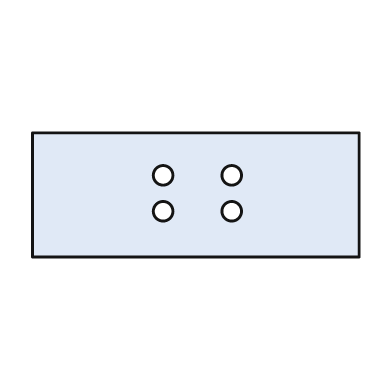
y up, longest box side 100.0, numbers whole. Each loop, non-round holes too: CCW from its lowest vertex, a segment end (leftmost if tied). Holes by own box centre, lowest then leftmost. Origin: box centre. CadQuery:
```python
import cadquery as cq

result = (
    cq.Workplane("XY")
    .moveTo(-50.0, -19.0)
    .lineTo(50.0, -19.0)
    .lineTo(50.0, 19.0)
    .lineTo(-50.0, 19.0)
    .close()
    .moveTo(-10.0, -5.0)
    .circle(3.0)
    .moveTo(11.0, -5.0)
    .circle(3.0)
    .moveTo(-10.0, 6.0)
    .circle(3.0)
    .moveTo(11.0, 6.0)
    .circle(3.0)
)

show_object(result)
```